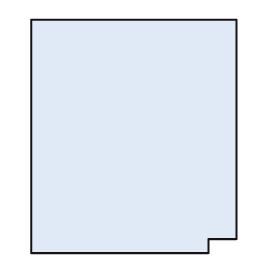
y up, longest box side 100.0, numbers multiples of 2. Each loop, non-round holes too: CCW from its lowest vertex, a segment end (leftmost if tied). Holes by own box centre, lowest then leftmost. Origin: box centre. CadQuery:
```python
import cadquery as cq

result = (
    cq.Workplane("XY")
    .moveTo(-44.0, -50.0)
    .lineTo(32.0, -50.0)
    .lineTo(32.0, -44.0)
    .lineTo(44.0, -44.0)
    .lineTo(44.0, 50.0)
    .lineTo(-44.0, 50.0)
    .close()
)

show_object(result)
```